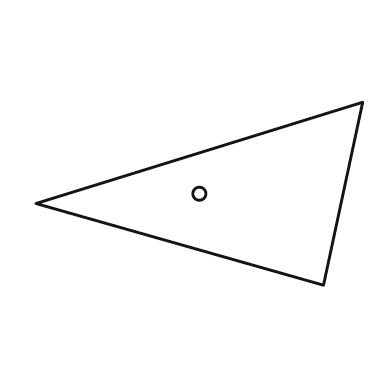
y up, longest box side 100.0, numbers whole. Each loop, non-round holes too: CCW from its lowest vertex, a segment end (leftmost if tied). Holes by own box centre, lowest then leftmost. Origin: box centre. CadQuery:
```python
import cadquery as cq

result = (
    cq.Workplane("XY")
    .moveTo(38.0, -28.0)
    .lineTo(50.0, 28.0)
    .lineTo(-50.0, -3.0)
    .close()
    .moveTo(0.0, 0.0)
    .circle(2.0)
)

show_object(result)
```